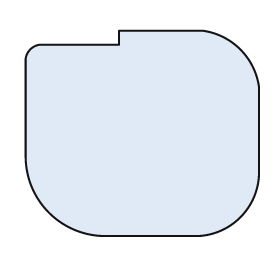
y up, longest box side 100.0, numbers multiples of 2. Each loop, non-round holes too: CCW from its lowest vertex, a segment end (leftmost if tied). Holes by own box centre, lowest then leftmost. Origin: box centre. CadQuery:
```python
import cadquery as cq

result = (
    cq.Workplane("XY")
    .moveTo(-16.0, -44.0)
    .lineTo(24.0, -44.0)
    .threePointArc((42.0, -36.0), (50.0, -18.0))
    .lineTo(50.0, 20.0)
    .threePointArc((42.0, 36.0), (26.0, 44.0))
    .lineTo(-10.0, 44.0)
    .lineTo(-10.0, 38.0)
    .lineTo(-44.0, 38.0)
    .threePointArc((-48.0, 36.0), (-50.0, 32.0))
    .lineTo(-50.0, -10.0)
    .threePointArc((-40.0, -34.0), (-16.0, -44.0))
    .close()
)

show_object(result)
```